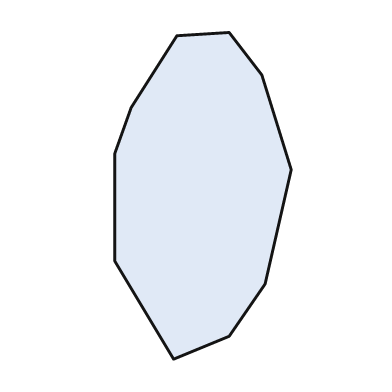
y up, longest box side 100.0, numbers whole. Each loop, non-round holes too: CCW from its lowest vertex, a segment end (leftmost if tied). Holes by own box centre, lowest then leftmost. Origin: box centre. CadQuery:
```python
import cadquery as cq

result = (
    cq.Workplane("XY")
    .moveTo(-9.0, -50.0)
    .lineTo(8.0, -43.0)
    .lineTo(19.0, -27.0)
    .lineTo(27.0, 8.0)
    .lineTo(18.0, 37.0)
    .lineTo(8.0, 50.0)
    .lineTo(-8.0, 49.0)
    .lineTo(-22.0, 27.0)
    .lineTo(-27.0, 13.0)
    .lineTo(-27.0, -20.0)
    .close()
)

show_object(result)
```